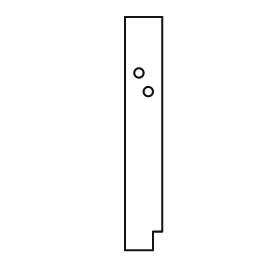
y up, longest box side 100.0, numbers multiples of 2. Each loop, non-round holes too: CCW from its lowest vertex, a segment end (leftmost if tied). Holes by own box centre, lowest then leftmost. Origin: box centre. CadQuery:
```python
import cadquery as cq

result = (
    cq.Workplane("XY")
    .moveTo(-8.0, -50.0)
    .lineTo(4.0, -50.0)
    .lineTo(4.0, -42.0)
    .lineTo(8.0, -42.0)
    .lineTo(8.0, 50.0)
    .lineTo(-8.0, 50.0)
    .close()
    .moveTo(2.0, 18.0)
    .circle(2.0)
    .moveTo(-2.0, 26.0)
    .circle(2.0)
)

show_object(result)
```